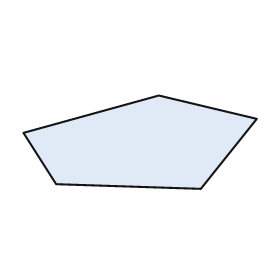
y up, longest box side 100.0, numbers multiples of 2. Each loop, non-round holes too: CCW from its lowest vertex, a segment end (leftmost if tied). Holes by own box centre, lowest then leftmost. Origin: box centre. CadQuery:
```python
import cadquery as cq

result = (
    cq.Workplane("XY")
    .moveTo(26.0, -20.0)
    .lineTo(50.0, 10.0)
    .lineTo(8.0, 20.0)
    .lineTo(-50.0, 4.0)
    .lineTo(-36.0, -18.0)
    .close()
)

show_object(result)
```